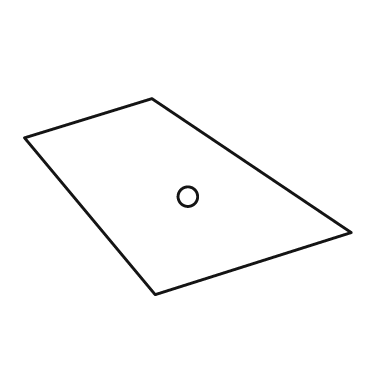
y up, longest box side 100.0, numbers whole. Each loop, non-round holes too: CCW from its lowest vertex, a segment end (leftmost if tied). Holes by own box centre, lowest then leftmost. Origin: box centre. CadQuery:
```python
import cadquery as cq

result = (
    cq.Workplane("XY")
    .moveTo(-10.0, -30.0)
    .lineTo(50.0, -11.0)
    .lineTo(-11.0, 30.0)
    .lineTo(-50.0, 18.0)
    .close()
    .moveTo(0.0, 0.0)
    .circle(3.0)
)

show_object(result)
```